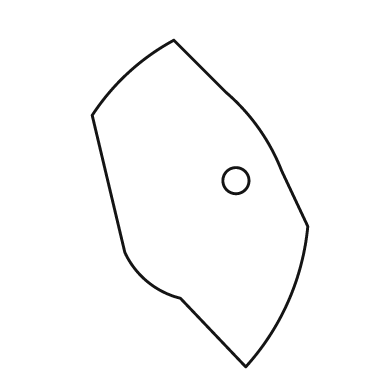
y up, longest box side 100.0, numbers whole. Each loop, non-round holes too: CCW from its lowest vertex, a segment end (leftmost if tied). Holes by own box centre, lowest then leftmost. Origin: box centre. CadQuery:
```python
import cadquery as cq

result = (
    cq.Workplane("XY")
    .moveTo(14.0, -50.0)
    .threePointArc((27.0, -30.0), (33.0, -7.0))
    .lineTo(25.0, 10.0)
    .threePointArc((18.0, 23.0), (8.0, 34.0))
    .lineTo(-8.0, 50.0)
    .threePointArc((-22.0, 40.0), (-33.0, 27.0))
    .lineTo(-23.0, -15.0)
    .threePointArc((-16.0, -24.0), (-6.0, -29.0))
    .close()
    .moveTo(11.0, 7.0)
    .circle(4.0)
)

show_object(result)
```